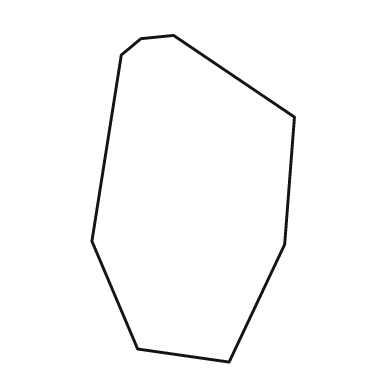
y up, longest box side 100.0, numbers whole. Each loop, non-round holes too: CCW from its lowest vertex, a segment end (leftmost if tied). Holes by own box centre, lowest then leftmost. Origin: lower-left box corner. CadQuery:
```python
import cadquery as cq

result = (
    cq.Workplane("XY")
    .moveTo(42.0, 0.0)
    .lineTo(59.0, 36.0)
    .lineTo(62.0, 75.0)
    .lineTo(25.0, 100.0)
    .lineTo(15.0, 99.0)
    .lineTo(9.0, 94.0)
    .lineTo(0.0, 37.0)
    .lineTo(14.0, 4.0)
    .close()
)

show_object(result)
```